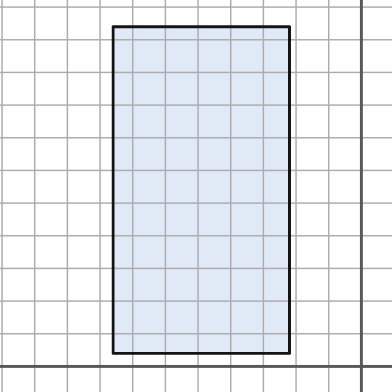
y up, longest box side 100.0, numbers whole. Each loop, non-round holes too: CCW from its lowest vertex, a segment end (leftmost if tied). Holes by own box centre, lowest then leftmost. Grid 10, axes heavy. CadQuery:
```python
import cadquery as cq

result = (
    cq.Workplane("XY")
    .moveTo(-76.0, 4.0)
    .lineTo(-22.0, 4.0)
    .lineTo(-22.0, 104.0)
    .lineTo(-76.0, 104.0)
    .close()
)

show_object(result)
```